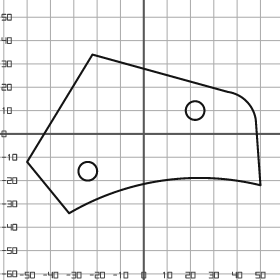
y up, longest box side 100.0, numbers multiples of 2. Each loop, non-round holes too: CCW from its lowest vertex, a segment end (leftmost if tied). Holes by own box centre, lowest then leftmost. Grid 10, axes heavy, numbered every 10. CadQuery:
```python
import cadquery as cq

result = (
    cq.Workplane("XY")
    .moveTo(-32.0, -34.0)
    .threePointArc((8.0, -20.0), (50.0, -22.0))
    .lineTo(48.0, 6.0)
    .threePointArc((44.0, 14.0), (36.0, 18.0))
    .lineTo(-22.0, 34.0)
    .lineTo(-50.0, -12.0)
    .close()
    .moveTo(-24.0, -16.0)
    .circle(4.0)
    .moveTo(22.0, 10.0)
    .circle(4.0)
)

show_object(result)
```